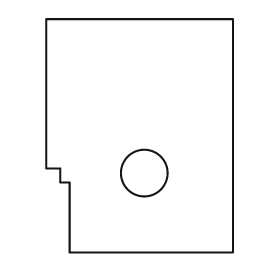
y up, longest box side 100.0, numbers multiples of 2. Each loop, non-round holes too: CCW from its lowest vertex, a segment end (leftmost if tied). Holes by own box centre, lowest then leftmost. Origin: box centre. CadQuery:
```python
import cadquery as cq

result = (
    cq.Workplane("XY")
    .moveTo(-30.0, -50.0)
    .lineTo(40.0, -50.0)
    .lineTo(40.0, 50.0)
    .lineTo(-40.0, 50.0)
    .lineTo(-40.0, -14.0)
    .lineTo(-34.0, -14.0)
    .lineTo(-34.0, -20.0)
    .lineTo(-30.0, -20.0)
    .close()
    .moveTo(2.0, -16.0)
    .circle(10.0)
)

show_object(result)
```